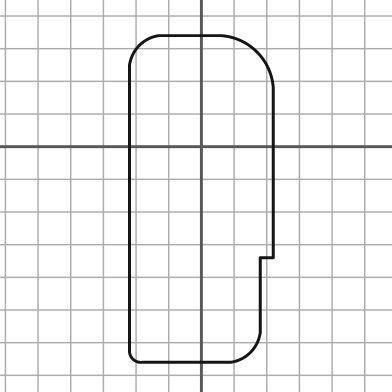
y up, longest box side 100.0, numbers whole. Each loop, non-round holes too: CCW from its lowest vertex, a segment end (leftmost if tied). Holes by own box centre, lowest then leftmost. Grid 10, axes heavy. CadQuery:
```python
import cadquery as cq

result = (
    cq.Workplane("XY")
    .moveTo(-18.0, -66.0)
    .lineTo(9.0, -66.0)
    .threePointArc((15.0, -63.0), (18.0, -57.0))
    .lineTo(18.0, -34.0)
    .lineTo(22.0, -34.0)
    .lineTo(22.0, 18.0)
    .threePointArc((17.0, 29.0), (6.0, 34.0))
    .lineTo(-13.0, 34.0)
    .threePointArc((-19.0, 31.0), (-22.0, 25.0))
    .lineTo(-22.0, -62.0)
    .threePointArc((-21.0, -65.0), (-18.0, -66.0))
    .close()
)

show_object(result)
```